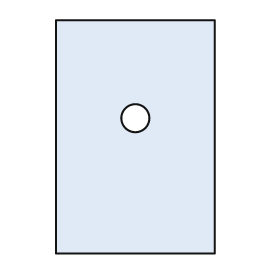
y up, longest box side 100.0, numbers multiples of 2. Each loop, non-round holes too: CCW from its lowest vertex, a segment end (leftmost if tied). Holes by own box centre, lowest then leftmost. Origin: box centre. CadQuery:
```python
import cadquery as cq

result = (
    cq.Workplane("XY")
    .moveTo(-34.0, -50.0)
    .lineTo(34.0, -50.0)
    .lineTo(34.0, 50.0)
    .lineTo(-34.0, 50.0)
    .close()
    .moveTo(0.0, 8.0)
    .circle(6.0)
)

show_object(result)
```